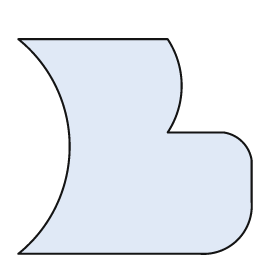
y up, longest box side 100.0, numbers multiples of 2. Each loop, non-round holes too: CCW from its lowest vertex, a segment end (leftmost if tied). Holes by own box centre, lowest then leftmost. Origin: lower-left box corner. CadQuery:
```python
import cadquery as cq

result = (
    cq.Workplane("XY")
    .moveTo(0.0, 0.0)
    .lineTo(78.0, 0.0)
    .threePointArc((94.0, 6.0), (100.0, 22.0))
    .lineTo(100.0, 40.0)
    .threePointArc((96.0, 48.0), (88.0, 52.0))
    .lineTo(64.0, 52.0)
    .threePointArc((70.0, 72.0), (64.0, 92.0))
    .lineTo(0.0, 92.0)
    .threePointArc((22.0, 46.0), (0.0, 0.0))
    .close()
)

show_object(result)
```